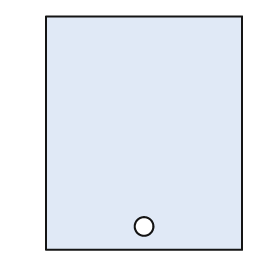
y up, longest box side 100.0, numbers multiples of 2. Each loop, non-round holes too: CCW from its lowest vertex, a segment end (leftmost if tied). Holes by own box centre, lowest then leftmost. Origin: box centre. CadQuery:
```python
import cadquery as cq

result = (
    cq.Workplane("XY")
    .moveTo(-42.0, -50.0)
    .lineTo(42.0, -50.0)
    .lineTo(42.0, 50.0)
    .lineTo(-42.0, 50.0)
    .close()
    .moveTo(0.0, -40.0)
    .circle(4.0)
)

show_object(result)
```